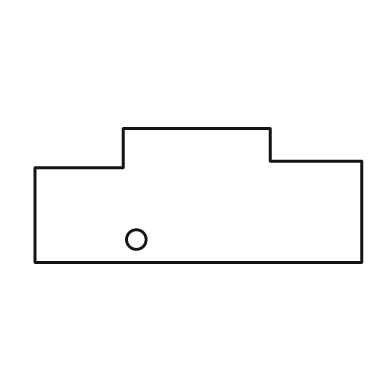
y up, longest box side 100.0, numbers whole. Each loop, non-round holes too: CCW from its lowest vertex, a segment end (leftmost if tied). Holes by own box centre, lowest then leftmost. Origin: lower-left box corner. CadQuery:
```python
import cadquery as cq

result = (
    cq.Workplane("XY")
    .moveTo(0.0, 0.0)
    .lineTo(100.0, 0.0)
    .lineTo(100.0, 31.0)
    .lineTo(72.0, 31.0)
    .lineTo(72.0, 41.0)
    .lineTo(27.0, 41.0)
    .lineTo(27.0, 29.0)
    .lineTo(0.0, 29.0)
    .close()
    .moveTo(31.0, 7.0)
    .circle(3.0)
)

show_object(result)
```